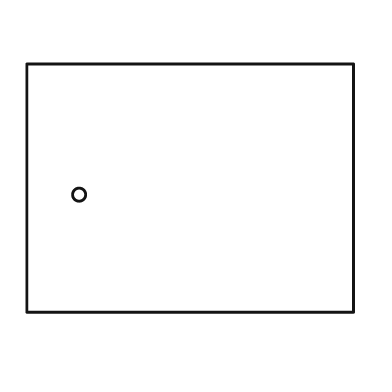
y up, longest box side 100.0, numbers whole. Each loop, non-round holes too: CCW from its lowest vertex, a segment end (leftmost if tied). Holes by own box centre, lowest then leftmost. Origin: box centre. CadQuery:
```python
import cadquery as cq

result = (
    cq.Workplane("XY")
    .moveTo(-50.0, -38.0)
    .lineTo(50.0, -38.0)
    .lineTo(50.0, 38.0)
    .lineTo(-50.0, 38.0)
    .close()
    .moveTo(-34.0, -2.0)
    .circle(2.0)
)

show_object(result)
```